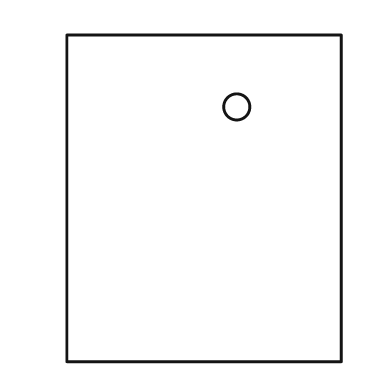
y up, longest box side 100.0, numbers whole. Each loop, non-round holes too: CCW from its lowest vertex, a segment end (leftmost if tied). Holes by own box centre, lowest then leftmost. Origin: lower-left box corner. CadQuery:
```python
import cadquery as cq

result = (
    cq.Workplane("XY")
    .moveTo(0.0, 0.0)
    .lineTo(84.0, 0.0)
    .lineTo(84.0, 100.0)
    .lineTo(0.0, 100.0)
    .close()
    .moveTo(52.0, 78.0)
    .circle(4.0)
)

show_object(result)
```